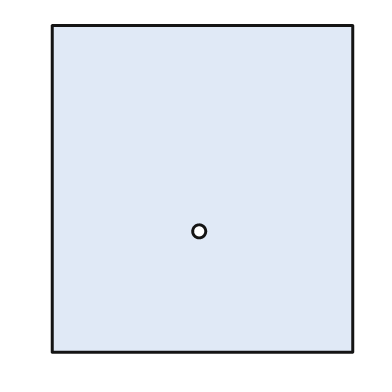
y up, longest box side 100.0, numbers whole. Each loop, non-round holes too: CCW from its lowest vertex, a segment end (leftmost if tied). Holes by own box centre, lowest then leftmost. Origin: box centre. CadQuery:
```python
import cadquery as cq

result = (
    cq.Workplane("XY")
    .moveTo(-46.0, -50.0)
    .lineTo(46.0, -50.0)
    .lineTo(46.0, 50.0)
    .lineTo(-46.0, 50.0)
    .close()
    .moveTo(-1.0, -13.0)
    .circle(2.0)
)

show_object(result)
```